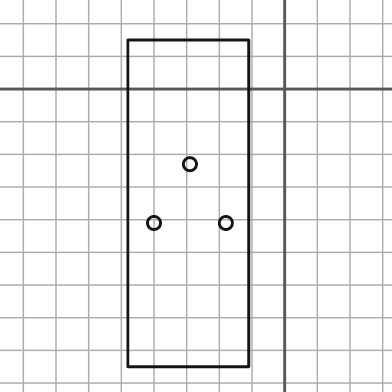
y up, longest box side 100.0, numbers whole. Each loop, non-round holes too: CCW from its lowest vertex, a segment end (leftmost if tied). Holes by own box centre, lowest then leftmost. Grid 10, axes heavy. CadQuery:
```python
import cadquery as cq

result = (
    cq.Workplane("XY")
    .moveTo(-48.0, -85.0)
    .lineTo(-11.0, -85.0)
    .lineTo(-11.0, 15.0)
    .lineTo(-48.0, 15.0)
    .close()
    .moveTo(-40.0, -41.0)
    .circle(2.0)
    .moveTo(-18.0, -41.0)
    .circle(2.0)
    .moveTo(-29.0, -23.0)
    .circle(2.0)
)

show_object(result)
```